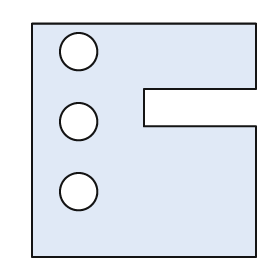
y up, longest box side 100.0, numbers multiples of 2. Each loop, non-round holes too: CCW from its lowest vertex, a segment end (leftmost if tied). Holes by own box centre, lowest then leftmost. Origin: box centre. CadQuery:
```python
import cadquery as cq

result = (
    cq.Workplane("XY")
    .moveTo(-48.0, -50.0)
    .lineTo(48.0, -50.0)
    .lineTo(48.0, 6.0)
    .lineTo(0.0, 6.0)
    .lineTo(0.0, 22.0)
    .lineTo(48.0, 22.0)
    .lineTo(48.0, 50.0)
    .lineTo(-48.0, 50.0)
    .close()
    .moveTo(-28.0, -22.0)
    .circle(8.0)
    .moveTo(-28.0, 8.0)
    .circle(8.0)
    .moveTo(-28.0, 38.0)
    .circle(8.0)
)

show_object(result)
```